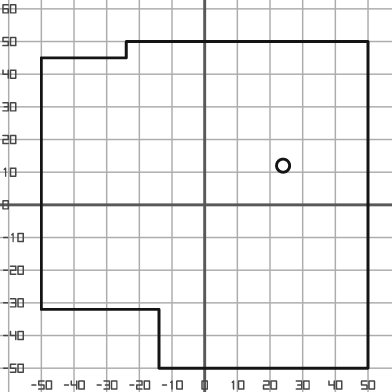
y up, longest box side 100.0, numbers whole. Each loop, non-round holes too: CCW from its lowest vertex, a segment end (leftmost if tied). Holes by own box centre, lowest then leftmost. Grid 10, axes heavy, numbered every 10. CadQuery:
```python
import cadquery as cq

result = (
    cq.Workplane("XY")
    .moveTo(-14.0, -50.0)
    .lineTo(50.0, -50.0)
    .lineTo(50.0, 50.0)
    .lineTo(-24.0, 50.0)
    .lineTo(-24.0, 45.0)
    .lineTo(-50.0, 45.0)
    .lineTo(-50.0, -32.0)
    .lineTo(-14.0, -32.0)
    .close()
    .moveTo(24.0, 12.0)
    .circle(2.0)
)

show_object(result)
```